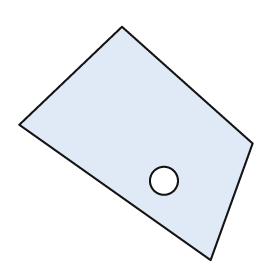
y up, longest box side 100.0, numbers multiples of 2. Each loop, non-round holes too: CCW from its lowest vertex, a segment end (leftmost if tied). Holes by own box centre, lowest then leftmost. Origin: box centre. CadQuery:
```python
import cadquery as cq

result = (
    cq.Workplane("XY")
    .moveTo(32.0, -50.0)
    .lineTo(50.0, 0.0)
    .lineTo(-6.0, 50.0)
    .lineTo(-50.0, 8.0)
    .close()
    .moveTo(12.0, -16.0)
    .circle(6.0)
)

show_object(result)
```